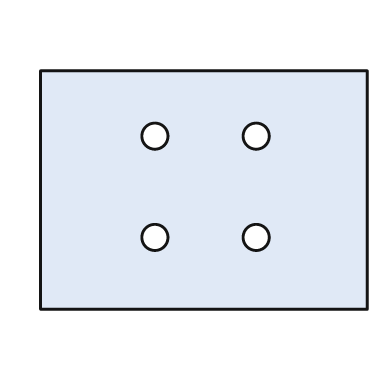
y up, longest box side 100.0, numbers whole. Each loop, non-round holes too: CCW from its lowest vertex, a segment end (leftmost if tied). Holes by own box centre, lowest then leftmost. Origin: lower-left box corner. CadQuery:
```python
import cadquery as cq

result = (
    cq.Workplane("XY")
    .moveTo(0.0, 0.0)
    .lineTo(100.0, 0.0)
    .lineTo(100.0, 73.0)
    .lineTo(0.0, 73.0)
    .close()
    .moveTo(35.0, 22.0)
    .circle(4.0)
    .moveTo(66.0, 22.0)
    .circle(4.0)
    .moveTo(35.0, 53.0)
    .circle(4.0)
    .moveTo(66.0, 53.0)
    .circle(4.0)
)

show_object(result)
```